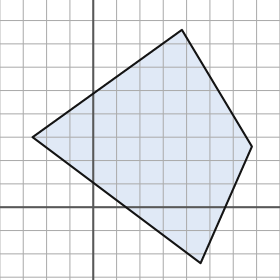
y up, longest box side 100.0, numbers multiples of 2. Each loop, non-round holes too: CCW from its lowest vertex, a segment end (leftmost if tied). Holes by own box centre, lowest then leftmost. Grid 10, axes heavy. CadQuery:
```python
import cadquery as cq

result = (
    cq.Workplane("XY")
    .moveTo(46.0, -24.0)
    .lineTo(68.0, 26.0)
    .lineTo(38.0, 76.0)
    .lineTo(-26.0, 30.0)
    .close()
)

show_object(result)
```